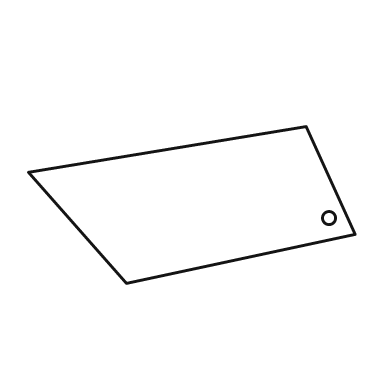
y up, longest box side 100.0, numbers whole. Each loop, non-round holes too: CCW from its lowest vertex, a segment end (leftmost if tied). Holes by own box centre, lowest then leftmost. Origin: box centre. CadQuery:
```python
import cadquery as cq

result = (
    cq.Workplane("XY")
    .moveTo(-20.0, -24.0)
    .lineTo(50.0, -9.0)
    .lineTo(35.0, 24.0)
    .lineTo(-50.0, 10.0)
    .close()
    .moveTo(42.0, -4.0)
    .circle(2.0)
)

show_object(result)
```